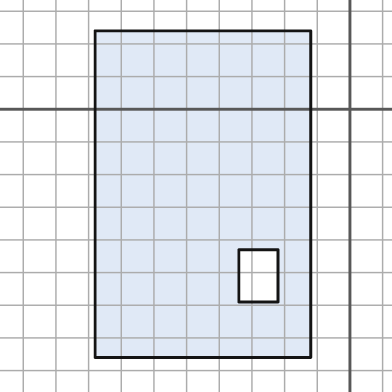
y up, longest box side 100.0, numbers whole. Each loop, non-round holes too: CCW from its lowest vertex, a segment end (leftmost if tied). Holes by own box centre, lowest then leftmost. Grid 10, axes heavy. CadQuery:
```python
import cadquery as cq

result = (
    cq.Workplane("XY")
    .moveTo(-78.0, -76.0)
    .lineTo(-12.0, -76.0)
    .lineTo(-12.0, 24.0)
    .lineTo(-78.0, 24.0)
    .close()
    .moveTo(-34.0, -59.0)
    .lineTo(-22.0, -59.0)
    .lineTo(-22.0, -43.0)
    .lineTo(-34.0, -43.0)
    .close()
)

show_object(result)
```